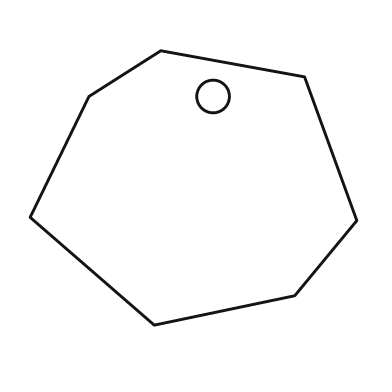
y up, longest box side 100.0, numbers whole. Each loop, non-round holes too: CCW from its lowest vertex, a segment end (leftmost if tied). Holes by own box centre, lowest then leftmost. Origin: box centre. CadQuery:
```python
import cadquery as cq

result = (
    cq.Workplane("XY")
    .moveTo(-12.0, -42.0)
    .lineTo(31.0, -33.0)
    .lineTo(50.0, -10.0)
    .lineTo(34.0, 34.0)
    .lineTo(-10.0, 42.0)
    .lineTo(-32.0, 28.0)
    .lineTo(-50.0, -9.0)
    .close()
    .moveTo(6.0, 28.0)
    .circle(5.0)
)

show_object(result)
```